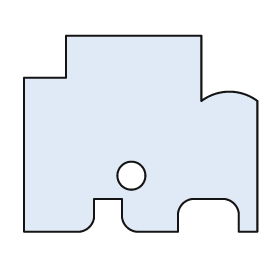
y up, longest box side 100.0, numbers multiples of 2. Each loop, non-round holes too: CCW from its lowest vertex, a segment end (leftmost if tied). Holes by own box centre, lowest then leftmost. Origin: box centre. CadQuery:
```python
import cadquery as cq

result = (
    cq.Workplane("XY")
    .moveTo(-50.0, -42.0)
    .lineTo(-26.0, -42.0)
    .threePointArc((-22.0, -40.0), (-20.0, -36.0))
    .lineTo(-20.0, -28.0)
    .lineTo(-8.0, -28.0)
    .lineTo(-8.0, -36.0)
    .threePointArc((-6.0, -40.0), (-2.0, -42.0))
    .lineTo(16.0, -42.0)
    .lineTo(16.0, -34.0)
    .threePointArc((18.0, -30.0), (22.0, -28.0))
    .lineTo(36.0, -28.0)
    .threePointArc((40.0, -30.0), (42.0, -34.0))
    .lineTo(42.0, -42.0)
    .lineTo(50.0, -42.0)
    .lineTo(50.0, 14.0)
    .threePointArc((38.0, 18.0), (26.0, 14.0))
    .lineTo(26.0, 42.0)
    .lineTo(-32.0, 42.0)
    .lineTo(-32.0, 24.0)
    .lineTo(-50.0, 24.0)
    .close()
    .moveTo(-4.0, -18.0)
    .circle(6.0)
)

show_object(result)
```